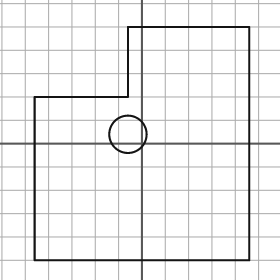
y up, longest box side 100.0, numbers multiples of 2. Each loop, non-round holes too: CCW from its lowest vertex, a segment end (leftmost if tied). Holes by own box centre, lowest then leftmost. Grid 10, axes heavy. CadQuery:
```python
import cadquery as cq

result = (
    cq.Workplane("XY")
    .moveTo(-46.0, -50.0)
    .lineTo(46.0, -50.0)
    .lineTo(46.0, 50.0)
    .lineTo(-6.0, 50.0)
    .lineTo(-6.0, 20.0)
    .lineTo(-46.0, 20.0)
    .close()
    .moveTo(-6.0, 4.0)
    .circle(8.0)
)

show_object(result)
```